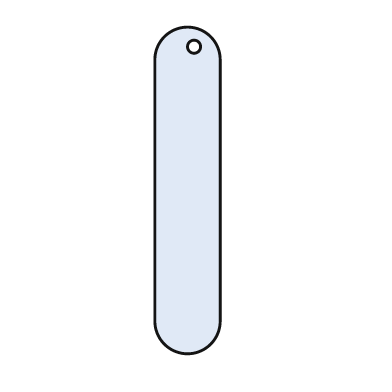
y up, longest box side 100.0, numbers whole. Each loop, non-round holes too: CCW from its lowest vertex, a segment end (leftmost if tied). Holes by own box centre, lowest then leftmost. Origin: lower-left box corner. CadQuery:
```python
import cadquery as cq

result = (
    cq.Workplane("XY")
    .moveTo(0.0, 10.0)
    .threePointArc((10.0, 0.0), (20.0, 10.0))
    .lineTo(20.0, 90.0)
    .threePointArc((10.0, 100.0), (0.0, 90.0))
    .close()
    .moveTo(12.0, 94.0)
    .circle(2.0)
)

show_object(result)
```